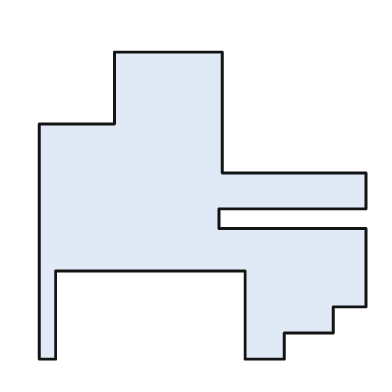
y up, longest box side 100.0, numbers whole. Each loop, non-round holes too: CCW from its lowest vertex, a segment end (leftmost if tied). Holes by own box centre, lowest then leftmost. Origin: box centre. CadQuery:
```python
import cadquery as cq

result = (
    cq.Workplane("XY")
    .moveTo(-50.0, -47.0)
    .lineTo(-45.0, -47.0)
    .lineTo(-45.0, -20.0)
    .lineTo(13.0, -20.0)
    .lineTo(13.0, -47.0)
    .lineTo(25.0, -47.0)
    .lineTo(25.0, -39.0)
    .lineTo(40.0, -39.0)
    .lineTo(40.0, -31.0)
    .lineTo(50.0, -31.0)
    .lineTo(50.0, -7.0)
    .lineTo(5.0, -7.0)
    .lineTo(5.0, -1.0)
    .lineTo(50.0, -1.0)
    .lineTo(50.0, 10.0)
    .lineTo(6.0, 10.0)
    .lineTo(6.0, 47.0)
    .lineTo(-27.0, 47.0)
    .lineTo(-27.0, 25.0)
    .lineTo(-50.0, 25.0)
    .close()
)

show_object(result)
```